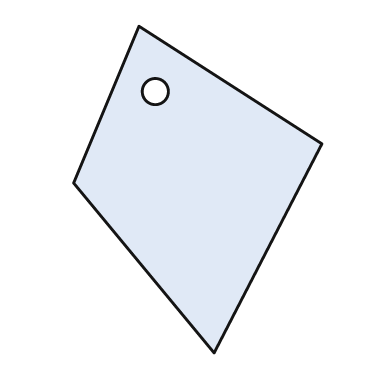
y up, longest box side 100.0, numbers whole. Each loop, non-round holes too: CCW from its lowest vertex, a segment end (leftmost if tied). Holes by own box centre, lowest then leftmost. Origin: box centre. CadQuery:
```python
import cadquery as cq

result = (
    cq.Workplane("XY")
    .moveTo(5.0, -50.0)
    .lineTo(38.0, 14.0)
    .lineTo(-18.0, 50.0)
    .lineTo(-38.0, 2.0)
    .close()
    .moveTo(-13.0, 30.0)
    .circle(4.0)
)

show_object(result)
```